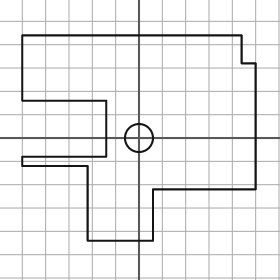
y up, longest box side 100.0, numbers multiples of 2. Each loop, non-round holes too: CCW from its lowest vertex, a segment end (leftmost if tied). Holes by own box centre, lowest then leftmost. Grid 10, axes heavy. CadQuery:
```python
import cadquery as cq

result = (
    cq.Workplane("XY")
    .moveTo(-22.0, -44.0)
    .lineTo(6.0, -44.0)
    .lineTo(6.0, -22.0)
    .lineTo(50.0, -22.0)
    .lineTo(50.0, 32.0)
    .lineTo(44.0, 32.0)
    .lineTo(44.0, 44.0)
    .lineTo(-50.0, 44.0)
    .lineTo(-50.0, 16.0)
    .lineTo(-14.0, 16.0)
    .lineTo(-14.0, -8.0)
    .lineTo(-50.0, -8.0)
    .lineTo(-50.0, -12.0)
    .lineTo(-22.0, -12.0)
    .close()
    .moveTo(0.0, 0.0)
    .circle(6.0)
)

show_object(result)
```